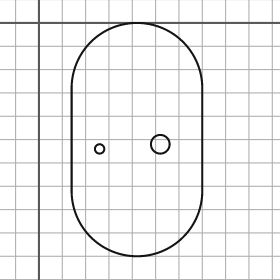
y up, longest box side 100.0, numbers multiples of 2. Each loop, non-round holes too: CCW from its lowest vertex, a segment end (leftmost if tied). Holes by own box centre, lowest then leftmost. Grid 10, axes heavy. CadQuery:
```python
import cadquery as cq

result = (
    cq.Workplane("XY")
    .moveTo(14.0, -72.0)
    .threePointArc((42.0, -100.0), (70.0, -72.0))
    .lineTo(70.0, -28.0)
    .threePointArc((42.0, 0.0), (14.0, -28.0))
    .close()
    .moveTo(26.0, -54.0)
    .circle(2.0)
    .moveTo(52.0, -52.0)
    .circle(4.0)
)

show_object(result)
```